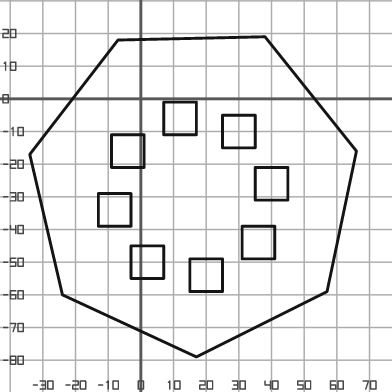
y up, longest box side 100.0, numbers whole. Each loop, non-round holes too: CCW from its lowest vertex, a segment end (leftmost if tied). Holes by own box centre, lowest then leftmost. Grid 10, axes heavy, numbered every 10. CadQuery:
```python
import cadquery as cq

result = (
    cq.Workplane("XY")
    .moveTo(17.0, -79.0)
    .lineTo(57.0, -59.0)
    .lineTo(66.0, -16.0)
    .lineTo(38.0, 19.0)
    .lineTo(-7.0, 18.0)
    .lineTo(-34.0, -17.0)
    .lineTo(-24.0, -60.0)
    .close()
    .moveTo(15.0, -59.0)
    .lineTo(25.0, -59.0)
    .lineTo(25.0, -49.0)
    .lineTo(15.0, -49.0)
    .close()
    .moveTo(-3.0, -55.0)
    .lineTo(7.0, -55.0)
    .lineTo(7.0, -45.0)
    .lineTo(-3.0, -45.0)
    .close()
    .moveTo(31.0, -49.0)
    .lineTo(41.0, -49.0)
    .lineTo(41.0, -39.0)
    .lineTo(31.0, -39.0)
    .close()
    .moveTo(-13.0, -39.0)
    .lineTo(-3.0, -39.0)
    .lineTo(-3.0, -29.0)
    .lineTo(-13.0, -29.0)
    .close()
    .moveTo(35.0, -31.0)
    .lineTo(45.0, -31.0)
    .lineTo(45.0, -21.0)
    .lineTo(35.0, -21.0)
    .close()
    .moveTo(-9.0, -21.0)
    .lineTo(1.0, -21.0)
    .lineTo(1.0, -11.0)
    .lineTo(-9.0, -11.0)
    .close()
    .moveTo(25.0, -15.0)
    .lineTo(35.0, -15.0)
    .lineTo(35.0, -5.0)
    .lineTo(25.0, -5.0)
    .close()
    .moveTo(7.0, -11.0)
    .lineTo(17.0, -11.0)
    .lineTo(17.0, -1.0)
    .lineTo(7.0, -1.0)
    .close()
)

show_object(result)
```